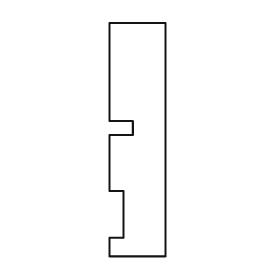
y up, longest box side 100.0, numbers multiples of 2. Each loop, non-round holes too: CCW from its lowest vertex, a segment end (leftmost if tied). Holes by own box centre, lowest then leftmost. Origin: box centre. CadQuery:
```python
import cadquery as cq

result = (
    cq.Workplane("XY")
    .moveTo(-12.0, -50.0)
    .lineTo(12.0, -50.0)
    .lineTo(12.0, 50.0)
    .lineTo(-12.0, 50.0)
    .lineTo(-12.0, 8.0)
    .lineTo(-2.0, 8.0)
    .lineTo(-2.0, 2.0)
    .lineTo(-12.0, 2.0)
    .lineTo(-12.0, -22.0)
    .lineTo(-6.0, -22.0)
    .lineTo(-6.0, -42.0)
    .lineTo(-12.0, -42.0)
    .close()
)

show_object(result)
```